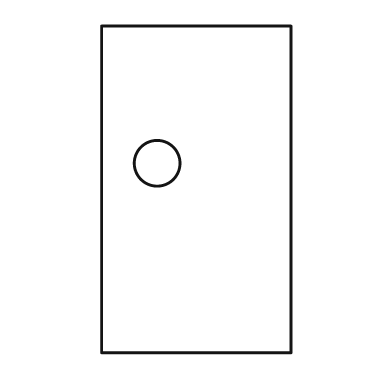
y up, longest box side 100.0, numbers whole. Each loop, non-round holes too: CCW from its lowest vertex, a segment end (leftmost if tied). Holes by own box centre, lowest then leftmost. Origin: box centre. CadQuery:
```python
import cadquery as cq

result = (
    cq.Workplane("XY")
    .moveTo(-29.0, -50.0)
    .lineTo(29.0, -50.0)
    .lineTo(29.0, 50.0)
    .lineTo(-29.0, 50.0)
    .close()
    .moveTo(-12.0, 8.0)
    .circle(7.0)
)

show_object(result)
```